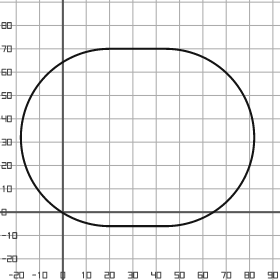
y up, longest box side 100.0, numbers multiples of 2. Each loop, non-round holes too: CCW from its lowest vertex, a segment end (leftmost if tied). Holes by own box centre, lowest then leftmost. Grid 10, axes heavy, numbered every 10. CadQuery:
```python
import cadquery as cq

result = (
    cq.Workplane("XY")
    .moveTo(20.0, -6.0)
    .lineTo(44.0, -6.0)
    .threePointArc((82.0, 32.0), (44.0, 70.0))
    .lineTo(20.0, 70.0)
    .threePointArc((-18.0, 32.0), (20.0, -6.0))
    .close()
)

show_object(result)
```